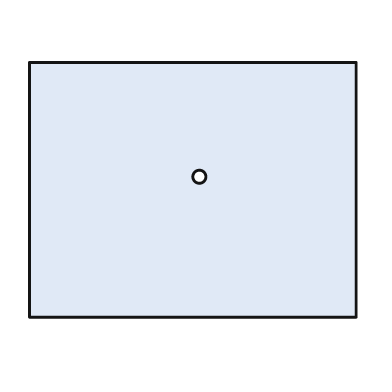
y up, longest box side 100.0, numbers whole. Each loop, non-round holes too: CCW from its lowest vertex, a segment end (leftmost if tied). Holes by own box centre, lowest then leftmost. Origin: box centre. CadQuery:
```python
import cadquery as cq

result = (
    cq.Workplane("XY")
    .moveTo(-50.0, -39.0)
    .lineTo(50.0, -39.0)
    .lineTo(50.0, 39.0)
    .lineTo(-50.0, 39.0)
    .close()
    .moveTo(2.0, 4.0)
    .circle(2.0)
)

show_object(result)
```